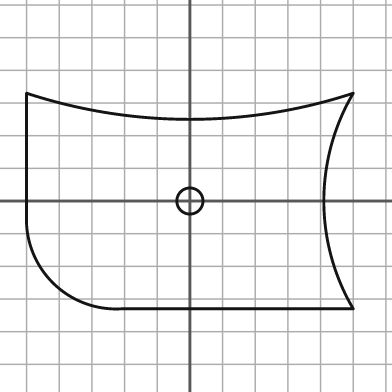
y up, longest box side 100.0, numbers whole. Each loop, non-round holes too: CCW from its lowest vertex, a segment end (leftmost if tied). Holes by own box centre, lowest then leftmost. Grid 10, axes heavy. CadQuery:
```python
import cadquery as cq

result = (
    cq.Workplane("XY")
    .moveTo(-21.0, -33.0)
    .lineTo(50.0, -33.0)
    .threePointArc((41.0, 0.0), (50.0, 33.0))
    .threePointArc((0.0, 25.0), (-50.0, 33.0))
    .lineTo(-50.0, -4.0)
    .threePointArc((-42.0, -25.0), (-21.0, -33.0))
    .close()
    .moveTo(0.0, 0.0)
    .circle(4.0)
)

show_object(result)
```